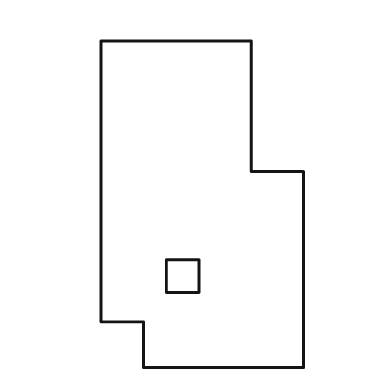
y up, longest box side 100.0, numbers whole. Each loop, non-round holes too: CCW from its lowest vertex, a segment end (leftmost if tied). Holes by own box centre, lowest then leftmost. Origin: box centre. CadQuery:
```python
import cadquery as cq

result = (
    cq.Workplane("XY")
    .moveTo(-18.0, -50.0)
    .lineTo(31.0, -50.0)
    .lineTo(31.0, 10.0)
    .lineTo(15.0, 10.0)
    .lineTo(15.0, 50.0)
    .lineTo(-31.0, 50.0)
    .lineTo(-31.0, -36.0)
    .lineTo(-18.0, -36.0)
    .close()
    .moveTo(-11.0, -27.0)
    .lineTo(-1.0, -27.0)
    .lineTo(-1.0, -17.0)
    .lineTo(-11.0, -17.0)
    .close()
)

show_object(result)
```